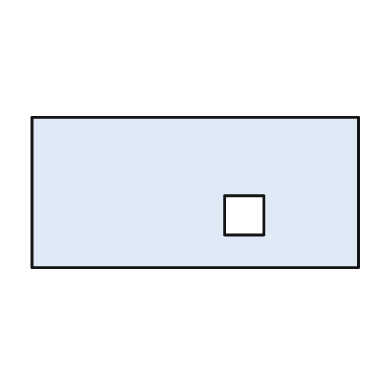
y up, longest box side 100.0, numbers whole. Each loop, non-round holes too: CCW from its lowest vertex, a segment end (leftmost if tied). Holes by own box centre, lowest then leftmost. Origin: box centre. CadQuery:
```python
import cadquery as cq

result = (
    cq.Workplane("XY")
    .moveTo(-50.0, -23.0)
    .lineTo(50.0, -23.0)
    .lineTo(50.0, 23.0)
    .lineTo(-50.0, 23.0)
    .close()
    .moveTo(9.0, -13.0)
    .lineTo(21.0, -13.0)
    .lineTo(21.0, -1.0)
    .lineTo(9.0, -1.0)
    .close()
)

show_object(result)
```